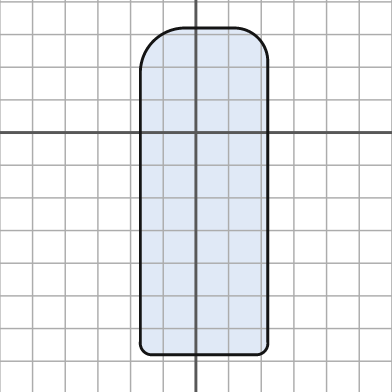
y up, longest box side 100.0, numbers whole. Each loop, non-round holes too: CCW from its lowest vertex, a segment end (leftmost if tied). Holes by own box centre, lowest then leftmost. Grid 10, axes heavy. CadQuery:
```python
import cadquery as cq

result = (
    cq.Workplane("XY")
    .moveTo(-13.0, -68.0)
    .lineTo(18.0, -68.0)
    .threePointArc((21.0, -67.0), (22.0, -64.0))
    .lineTo(22.0, 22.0)
    .threePointArc((19.0, 29.0), (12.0, 32.0))
    .lineTo(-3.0, 32.0)
    .threePointArc((-13.0, 28.0), (-17.0, 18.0))
    .lineTo(-17.0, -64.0)
    .threePointArc((-16.0, -67.0), (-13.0, -68.0))
    .close()
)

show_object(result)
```